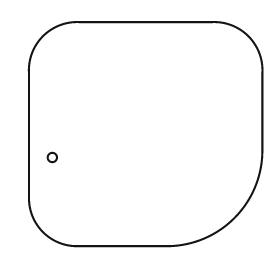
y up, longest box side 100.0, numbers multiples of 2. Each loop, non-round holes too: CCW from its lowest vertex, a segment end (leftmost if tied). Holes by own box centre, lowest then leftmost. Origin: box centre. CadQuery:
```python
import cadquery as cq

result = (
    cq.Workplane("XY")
    .moveTo(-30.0, -48.0)
    .lineTo(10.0, -48.0)
    .threePointArc((38.0, -36.0), (50.0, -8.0))
    .lineTo(50.0, 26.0)
    .threePointArc((44.0, 42.0), (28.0, 48.0))
    .lineTo(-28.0, 48.0)
    .threePointArc((-44.0, 42.0), (-50.0, 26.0))
    .lineTo(-50.0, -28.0)
    .threePointArc((-44.0, -42.0), (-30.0, -48.0))
    .close()
    .moveTo(-40.0, -10.0)
    .circle(2.0)
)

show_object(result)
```